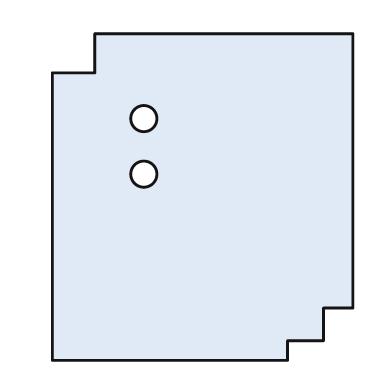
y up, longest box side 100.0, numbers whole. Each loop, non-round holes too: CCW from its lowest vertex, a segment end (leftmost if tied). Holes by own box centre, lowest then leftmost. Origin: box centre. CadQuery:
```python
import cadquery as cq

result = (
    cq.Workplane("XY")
    .moveTo(-46.0, -50.0)
    .lineTo(26.0, -50.0)
    .lineTo(26.0, -44.0)
    .lineTo(37.0, -44.0)
    .lineTo(37.0, -34.0)
    .lineTo(46.0, -34.0)
    .lineTo(46.0, 50.0)
    .lineTo(-33.0, 50.0)
    .lineTo(-33.0, 38.0)
    .lineTo(-46.0, 38.0)
    .close()
    .moveTo(-18.0, 7.0)
    .circle(4.0)
    .moveTo(-18.0, 24.0)
    .circle(4.0)
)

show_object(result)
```